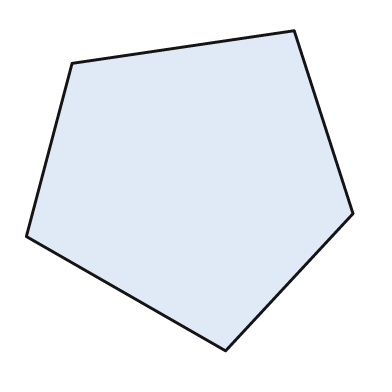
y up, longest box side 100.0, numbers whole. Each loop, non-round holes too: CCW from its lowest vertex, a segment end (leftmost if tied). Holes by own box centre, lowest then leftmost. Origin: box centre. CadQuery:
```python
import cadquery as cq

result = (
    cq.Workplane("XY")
    .moveTo(11.0, -49.0)
    .lineTo(50.0, -7.0)
    .lineTo(32.0, 49.0)
    .lineTo(-36.0, 39.0)
    .lineTo(-50.0, -14.0)
    .close()
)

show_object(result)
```